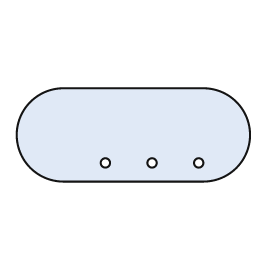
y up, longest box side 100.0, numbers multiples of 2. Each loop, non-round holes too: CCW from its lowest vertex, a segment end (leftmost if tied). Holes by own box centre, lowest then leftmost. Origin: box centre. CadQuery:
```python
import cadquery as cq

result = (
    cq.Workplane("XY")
    .moveTo(-30.0, -20.0)
    .lineTo(30.0, -20.0)
    .threePointArc((50.0, 0.0), (30.0, 20.0))
    .lineTo(-30.0, 20.0)
    .threePointArc((-50.0, 0.0), (-30.0, -20.0))
    .close()
    .moveTo(-12.0, -12.0)
    .circle(2.0)
    .moveTo(8.0, -12.0)
    .circle(2.0)
    .moveTo(28.0, -12.0)
    .circle(2.0)
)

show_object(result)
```